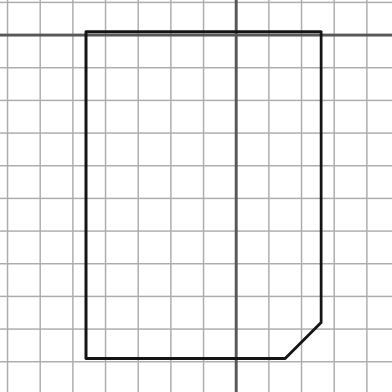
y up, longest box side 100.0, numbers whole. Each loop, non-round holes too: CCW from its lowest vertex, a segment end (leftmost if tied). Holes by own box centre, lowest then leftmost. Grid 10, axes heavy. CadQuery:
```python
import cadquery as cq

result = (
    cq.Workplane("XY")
    .moveTo(-46.0, -99.0)
    .lineTo(15.0, -99.0)
    .lineTo(26.0, -88.0)
    .lineTo(26.0, 1.0)
    .lineTo(-46.0, 1.0)
    .close()
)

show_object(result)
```